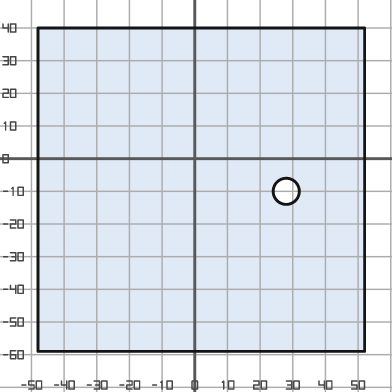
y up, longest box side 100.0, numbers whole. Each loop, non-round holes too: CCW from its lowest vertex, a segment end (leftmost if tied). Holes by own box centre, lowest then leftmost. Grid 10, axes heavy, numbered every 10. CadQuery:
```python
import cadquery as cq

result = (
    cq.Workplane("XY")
    .moveTo(-48.0, -59.0)
    .lineTo(52.0, -59.0)
    .lineTo(52.0, 40.0)
    .lineTo(-48.0, 40.0)
    .close()
    .moveTo(28.0, -10.0)
    .circle(4.0)
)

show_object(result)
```